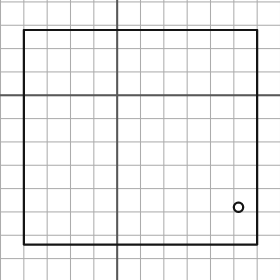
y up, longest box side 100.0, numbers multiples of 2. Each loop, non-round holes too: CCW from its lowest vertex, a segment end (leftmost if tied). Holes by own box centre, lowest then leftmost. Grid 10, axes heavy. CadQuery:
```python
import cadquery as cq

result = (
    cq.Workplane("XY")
    .moveTo(-40.0, -64.0)
    .lineTo(60.0, -64.0)
    .lineTo(60.0, 28.0)
    .lineTo(-40.0, 28.0)
    .close()
    .moveTo(52.0, -48.0)
    .circle(2.0)
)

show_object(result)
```